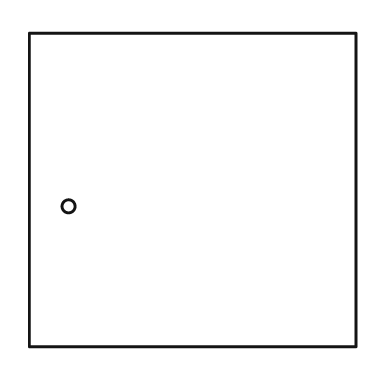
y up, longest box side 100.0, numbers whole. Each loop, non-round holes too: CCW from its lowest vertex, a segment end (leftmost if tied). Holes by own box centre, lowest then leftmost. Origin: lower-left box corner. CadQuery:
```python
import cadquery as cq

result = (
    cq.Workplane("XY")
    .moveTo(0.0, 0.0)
    .lineTo(100.0, 0.0)
    .lineTo(100.0, 96.0)
    .lineTo(0.0, 96.0)
    .close()
    .moveTo(12.0, 43.0)
    .circle(2.0)
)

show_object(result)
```